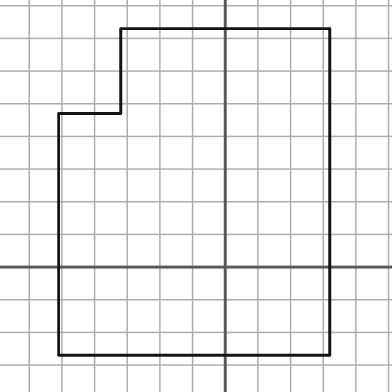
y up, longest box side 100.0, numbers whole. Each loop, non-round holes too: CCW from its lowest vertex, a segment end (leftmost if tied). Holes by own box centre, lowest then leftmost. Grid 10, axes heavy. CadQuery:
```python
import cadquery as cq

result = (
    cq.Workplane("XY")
    .moveTo(-51.0, -27.0)
    .lineTo(32.0, -27.0)
    .lineTo(32.0, 73.0)
    .lineTo(-32.0, 73.0)
    .lineTo(-32.0, 47.0)
    .lineTo(-51.0, 47.0)
    .close()
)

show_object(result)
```